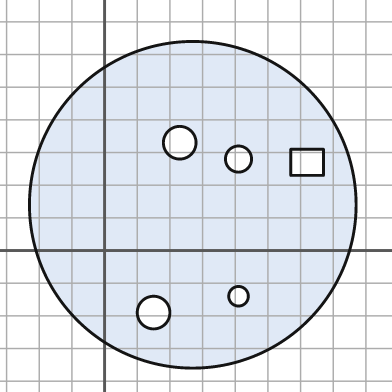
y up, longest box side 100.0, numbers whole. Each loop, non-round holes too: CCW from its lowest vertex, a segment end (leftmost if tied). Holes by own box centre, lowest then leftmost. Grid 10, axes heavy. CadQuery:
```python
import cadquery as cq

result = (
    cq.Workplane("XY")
    .moveTo(27.0, 14.0)
    .circle(50.0)
    .moveTo(15.0, -19.0)
    .circle(5.0)
    .moveTo(41.0, -14.0)
    .circle(3.0)
    .moveTo(57.0, 23.0)
    .lineTo(67.0, 23.0)
    .lineTo(67.0, 31.0)
    .lineTo(57.0, 31.0)
    .close()
    .moveTo(41.0, 28.0)
    .circle(4.0)
    .moveTo(23.0, 33.0)
    .circle(5.0)
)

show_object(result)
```